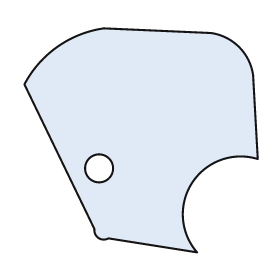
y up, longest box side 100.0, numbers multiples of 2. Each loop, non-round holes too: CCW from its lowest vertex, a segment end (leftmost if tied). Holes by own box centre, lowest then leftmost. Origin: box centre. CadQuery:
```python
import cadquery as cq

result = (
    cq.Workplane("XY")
    .moveTo(24.0, -48.0)
    .threePointArc((22.0, -18.0), (50.0, -8.0))
    .lineTo(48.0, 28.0)
    .threePointArc((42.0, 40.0), (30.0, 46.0))
    .lineTo(-16.0, 48.0)
    .threePointArc((-36.0, 40.0), (-50.0, 24.0))
    .lineTo(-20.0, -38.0)
    .threePointArc((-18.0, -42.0), (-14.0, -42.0))
    .close()
    .moveTo(-18.0, -12.0)
    .circle(6.0)
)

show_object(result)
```